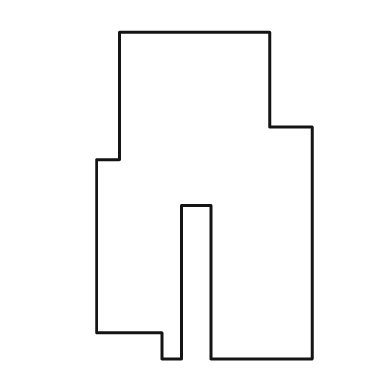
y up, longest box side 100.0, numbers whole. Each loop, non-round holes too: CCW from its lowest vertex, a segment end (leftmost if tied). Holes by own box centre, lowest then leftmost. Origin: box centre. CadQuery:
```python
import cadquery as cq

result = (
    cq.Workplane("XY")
    .moveTo(-13.0, -50.0)
    .lineTo(-7.0, -50.0)
    .lineTo(-7.0, -3.0)
    .lineTo(2.0, -3.0)
    .lineTo(2.0, -50.0)
    .lineTo(33.0, -50.0)
    .lineTo(33.0, 21.0)
    .lineTo(20.0, 21.0)
    .lineTo(20.0, 50.0)
    .lineTo(-26.0, 50.0)
    .lineTo(-26.0, 11.0)
    .lineTo(-33.0, 11.0)
    .lineTo(-33.0, -42.0)
    .lineTo(-13.0, -42.0)
    .close()
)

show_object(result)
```